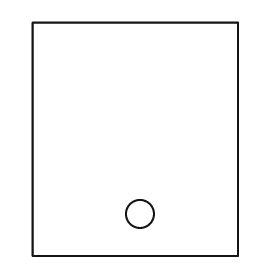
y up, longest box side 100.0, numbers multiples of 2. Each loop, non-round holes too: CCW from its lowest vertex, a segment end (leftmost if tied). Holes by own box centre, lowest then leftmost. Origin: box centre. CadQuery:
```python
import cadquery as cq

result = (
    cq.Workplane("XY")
    .moveTo(-44.0, -50.0)
    .lineTo(44.0, -50.0)
    .lineTo(44.0, 50.0)
    .lineTo(-44.0, 50.0)
    .close()
    .moveTo(2.0, -32.0)
    .circle(6.0)
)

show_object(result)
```